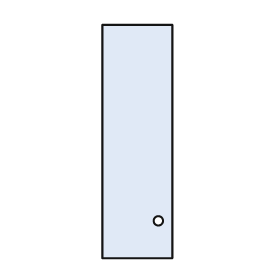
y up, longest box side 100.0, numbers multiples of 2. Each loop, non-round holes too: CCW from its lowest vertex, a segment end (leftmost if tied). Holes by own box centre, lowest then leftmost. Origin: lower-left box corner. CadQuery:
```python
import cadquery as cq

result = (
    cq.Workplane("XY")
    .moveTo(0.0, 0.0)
    .lineTo(30.0, 0.0)
    .lineTo(30.0, 100.0)
    .lineTo(0.0, 100.0)
    .close()
    .moveTo(24.0, 16.0)
    .circle(2.0)
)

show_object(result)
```